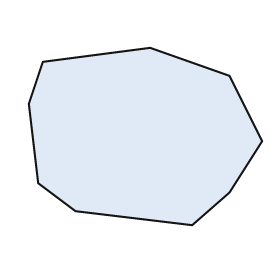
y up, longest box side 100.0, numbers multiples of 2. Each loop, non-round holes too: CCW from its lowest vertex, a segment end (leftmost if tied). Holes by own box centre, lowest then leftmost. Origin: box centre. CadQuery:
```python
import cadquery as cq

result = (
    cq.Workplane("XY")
    .moveTo(20.0, -38.0)
    .lineTo(36.0, -24.0)
    .lineTo(50.0, -2.0)
    .lineTo(36.0, 26.0)
    .lineTo(2.0, 38.0)
    .lineTo(-44.0, 32.0)
    .lineTo(-50.0, 14.0)
    .lineTo(-46.0, -20.0)
    .lineTo(-30.0, -32.0)
    .close()
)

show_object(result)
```